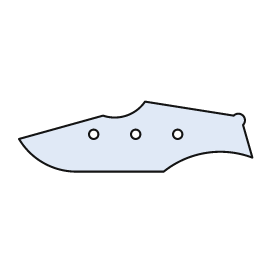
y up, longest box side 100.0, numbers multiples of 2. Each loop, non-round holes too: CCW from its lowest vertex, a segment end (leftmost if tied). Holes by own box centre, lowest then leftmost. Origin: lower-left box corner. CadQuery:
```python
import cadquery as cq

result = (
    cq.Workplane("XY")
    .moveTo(24.0, 0.0)
    .lineTo(62.0, 0.0)
    .threePointArc((80.0, 8.0), (100.0, 6.0))
    .lineTo(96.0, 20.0)
    .threePointArc((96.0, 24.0), (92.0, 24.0))
    .lineTo(54.0, 30.0)
    .threePointArc((46.0, 24.0), (36.0, 24.0))
    .lineTo(0.0, 14.0)
    .threePointArc((10.0, 4.0), (24.0, 0.0))
    .close()
    .moveTo(32.0, 16.0)
    .circle(2.0)
    .moveTo(50.0, 16.0)
    .circle(2.0)
    .moveTo(68.0, 16.0)
    .circle(2.0)
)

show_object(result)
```